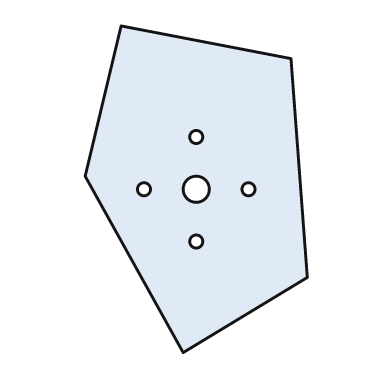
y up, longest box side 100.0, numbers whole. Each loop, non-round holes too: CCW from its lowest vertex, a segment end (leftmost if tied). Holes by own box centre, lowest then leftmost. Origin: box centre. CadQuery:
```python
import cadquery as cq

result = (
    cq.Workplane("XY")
    .moveTo(-4.0, -50.0)
    .lineTo(34.0, -27.0)
    .lineTo(29.0, 40.0)
    .lineTo(-23.0, 50.0)
    .lineTo(-34.0, 4.0)
    .close()
    .moveTo(0.0, -16.0)
    .circle(2.0)
    .moveTo(-16.0, 0.0)
    .circle(2.0)
    .moveTo(0.0, 0.0)
    .circle(4.0)
    .moveTo(16.0, 0.0)
    .circle(2.0)
    .moveTo(0.0, 16.0)
    .circle(2.0)
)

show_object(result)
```